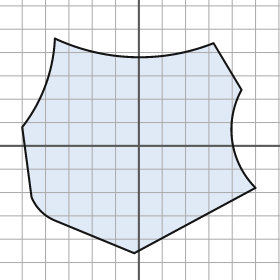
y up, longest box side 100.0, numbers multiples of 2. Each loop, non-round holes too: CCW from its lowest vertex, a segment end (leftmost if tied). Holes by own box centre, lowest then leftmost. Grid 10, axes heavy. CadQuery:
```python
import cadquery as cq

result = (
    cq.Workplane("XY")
    .moveTo(-2.0, -46.0)
    .lineTo(50.0, -18.0)
    .threePointArc((40.0, 2.0), (44.0, 24.0))
    .lineTo(32.0, 44.0)
    .threePointArc((-2.0, 38.0), (-36.0, 46.0))
    .threePointArc((-40.0, 26.0), (-50.0, 8.0))
    .lineTo(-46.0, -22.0)
    .threePointArc((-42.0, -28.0), (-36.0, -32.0))
    .close()
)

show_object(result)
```